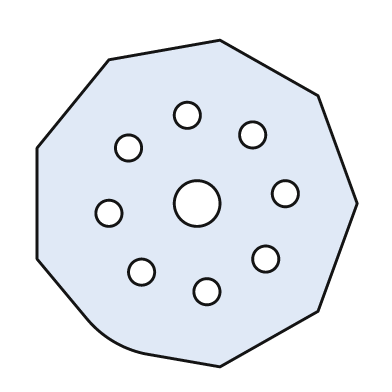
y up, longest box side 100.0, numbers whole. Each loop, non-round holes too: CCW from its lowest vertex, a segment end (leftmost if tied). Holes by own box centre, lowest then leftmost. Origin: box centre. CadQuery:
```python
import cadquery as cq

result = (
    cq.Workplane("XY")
    .moveTo(7.0, -50.0)
    .lineTo(37.0, -33.0)
    .lineTo(49.0, 0.0)
    .lineTo(37.0, 33.0)
    .lineTo(7.0, 50.0)
    .lineTo(-27.0, 44.0)
    .lineTo(-49.0, 17.0)
    .lineTo(-49.0, -17.0)
    .lineTo(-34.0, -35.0)
    .threePointArc((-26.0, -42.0), (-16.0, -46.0))
    .close()
    .moveTo(3.0, -27.0)
    .circle(4.0)
    .moveTo(-17.0, -21.0)
    .circle(4.0)
    .moveTo(21.0, -17.0)
    .circle(4.0)
    .moveTo(-27.0, -3.0)
    .circle(4.0)
    .moveTo(0.0, 0.0)
    .circle(7.0)
    .moveTo(27.0, 3.0)
    .circle(4.0)
    .moveTo(-21.0, 17.0)
    .circle(4.0)
    .moveTo(17.0, 21.0)
    .circle(4.0)
    .moveTo(-3.0, 27.0)
    .circle(4.0)
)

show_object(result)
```